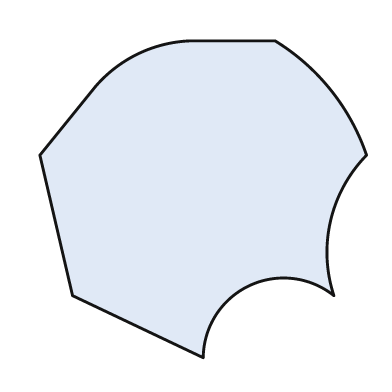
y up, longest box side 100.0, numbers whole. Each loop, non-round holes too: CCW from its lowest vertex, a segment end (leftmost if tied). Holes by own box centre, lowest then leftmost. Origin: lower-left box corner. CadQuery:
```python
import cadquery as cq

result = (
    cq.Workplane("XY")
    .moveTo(50.0, 0.0)
    .threePointArc((64.0, 22.0), (90.0, 19.0))
    .threePointArc((89.0, 42.0), (100.0, 62.0))
    .threePointArc((89.0, 82.0), (72.0, 97.0))
    .lineTo(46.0, 97.0)
    .threePointArc((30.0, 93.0), (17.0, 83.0))
    .lineTo(0.0, 62.0)
    .lineTo(10.0, 19.0)
    .close()
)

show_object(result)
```